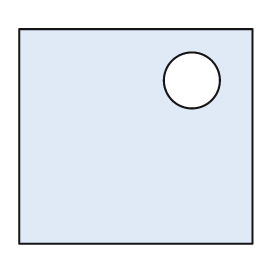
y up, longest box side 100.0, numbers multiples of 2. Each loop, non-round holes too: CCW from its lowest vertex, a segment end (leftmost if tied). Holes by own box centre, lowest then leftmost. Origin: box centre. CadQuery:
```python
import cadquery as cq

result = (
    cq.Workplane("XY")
    .moveTo(-50.0, -46.0)
    .lineTo(50.0, -46.0)
    .lineTo(50.0, 46.0)
    .lineTo(-50.0, 46.0)
    .close()
    .moveTo(24.0, 24.0)
    .circle(12.0)
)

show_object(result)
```